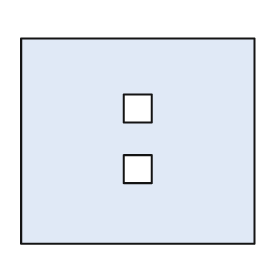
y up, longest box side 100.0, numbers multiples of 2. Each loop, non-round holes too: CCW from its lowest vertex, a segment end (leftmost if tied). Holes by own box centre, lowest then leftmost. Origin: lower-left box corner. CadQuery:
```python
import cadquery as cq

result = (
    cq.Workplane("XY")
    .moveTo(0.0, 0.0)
    .lineTo(100.0, 0.0)
    .lineTo(100.0, 88.0)
    .lineTo(0.0, 88.0)
    .close()
    .moveTo(44.0, 26.0)
    .lineTo(56.0, 26.0)
    .lineTo(56.0, 38.0)
    .lineTo(44.0, 38.0)
    .close()
    .moveTo(44.0, 52.0)
    .lineTo(56.0, 52.0)
    .lineTo(56.0, 64.0)
    .lineTo(44.0, 64.0)
    .close()
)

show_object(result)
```